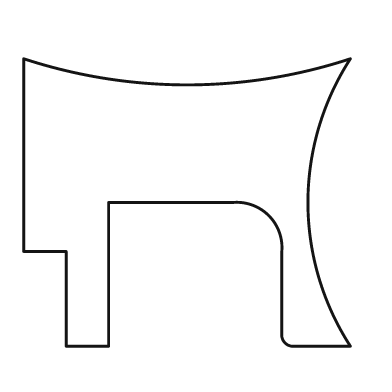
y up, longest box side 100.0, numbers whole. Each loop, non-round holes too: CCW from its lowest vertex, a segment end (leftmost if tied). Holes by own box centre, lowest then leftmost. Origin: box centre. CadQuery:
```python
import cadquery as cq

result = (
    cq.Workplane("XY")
    .moveTo(-37.0, -44.0)
    .lineTo(-24.0, -44.0)
    .lineTo(-24.0, 0.0)
    .lineTo(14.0, 0.0)
    .threePointArc((25.0, -4.0), (29.0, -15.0))
    .lineTo(29.0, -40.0)
    .threePointArc((30.0, -43.0), (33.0, -44.0))
    .lineTo(50.0, -44.0)
    .threePointArc((37.0, 0.0), (50.0, 44.0))
    .threePointArc((0.0, 36.0), (-50.0, 44.0))
    .lineTo(-50.0, -15.0)
    .lineTo(-37.0, -15.0)
    .close()
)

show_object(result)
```